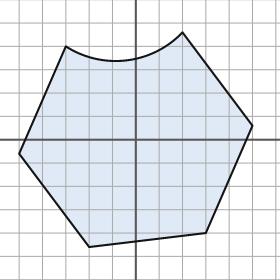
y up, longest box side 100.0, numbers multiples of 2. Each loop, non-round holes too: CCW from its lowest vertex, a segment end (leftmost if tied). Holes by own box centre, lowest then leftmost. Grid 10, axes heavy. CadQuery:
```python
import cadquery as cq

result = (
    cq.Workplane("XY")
    .moveTo(-20.0, -46.0)
    .lineTo(30.0, -40.0)
    .lineTo(50.0, 6.0)
    .lineTo(20.0, 46.0)
    .threePointArc((-4.0, 34.0), (-30.0, 40.0))
    .lineTo(-50.0, -6.0)
    .close()
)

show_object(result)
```